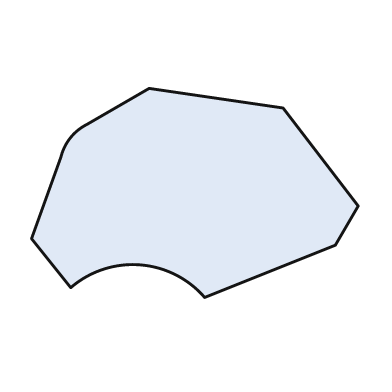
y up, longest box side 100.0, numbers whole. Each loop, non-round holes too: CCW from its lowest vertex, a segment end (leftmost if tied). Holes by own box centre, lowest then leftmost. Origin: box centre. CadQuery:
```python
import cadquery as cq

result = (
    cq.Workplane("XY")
    .moveTo(3.0, -32.0)
    .lineTo(43.0, -16.0)
    .lineTo(50.0, -4.0)
    .lineTo(27.0, 26.0)
    .lineTo(-14.0, 32.0)
    .lineTo(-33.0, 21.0)
    .threePointArc((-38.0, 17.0), (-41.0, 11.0))
    .lineTo(-50.0, -14.0)
    .lineTo(-38.0, -29.0)
    .threePointArc((-17.0, -22.0), (3.0, -32.0))
    .close()
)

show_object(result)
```